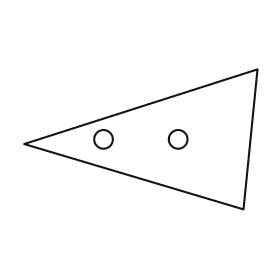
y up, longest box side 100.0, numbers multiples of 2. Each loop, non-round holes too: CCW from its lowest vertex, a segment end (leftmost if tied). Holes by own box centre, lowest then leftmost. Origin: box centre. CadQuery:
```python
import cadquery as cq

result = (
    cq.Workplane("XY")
    .moveTo(44.0, -30.0)
    .lineTo(50.0, 30.0)
    .lineTo(-50.0, -2.0)
    .close()
    .moveTo(-16.0, 0.0)
    .circle(4.0)
    .moveTo(16.0, 0.0)
    .circle(4.0)
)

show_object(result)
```